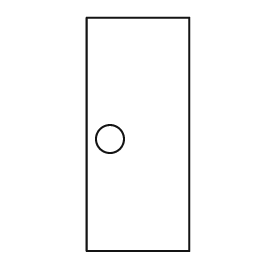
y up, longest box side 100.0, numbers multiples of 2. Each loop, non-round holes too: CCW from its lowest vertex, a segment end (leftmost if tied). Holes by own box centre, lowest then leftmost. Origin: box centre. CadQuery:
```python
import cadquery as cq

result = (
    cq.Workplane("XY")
    .moveTo(-22.0, -50.0)
    .lineTo(22.0, -50.0)
    .lineTo(22.0, 50.0)
    .lineTo(-22.0, 50.0)
    .close()
    .moveTo(-12.0, -2.0)
    .circle(6.0)
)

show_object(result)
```